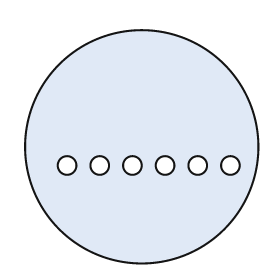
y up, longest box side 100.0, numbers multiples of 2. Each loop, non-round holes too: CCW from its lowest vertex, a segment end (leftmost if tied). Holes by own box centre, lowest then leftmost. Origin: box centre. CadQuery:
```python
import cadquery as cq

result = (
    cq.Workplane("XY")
    .moveTo(0.0, 0.0)
    .circle(50.0)
    .moveTo(-32.0, -8.0)
    .circle(4.0)
    .moveTo(-18.0, -8.0)
    .circle(4.0)
    .moveTo(-4.0, -8.0)
    .circle(4.0)
    .moveTo(10.0, -8.0)
    .circle(4.0)
    .moveTo(24.0, -8.0)
    .circle(4.0)
    .moveTo(38.0, -8.0)
    .circle(4.0)
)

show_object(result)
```